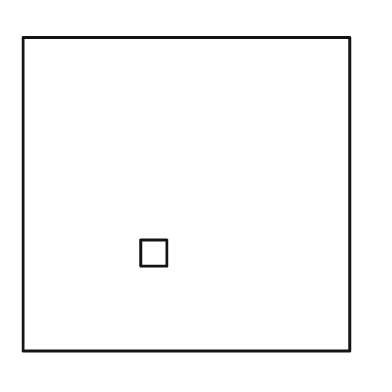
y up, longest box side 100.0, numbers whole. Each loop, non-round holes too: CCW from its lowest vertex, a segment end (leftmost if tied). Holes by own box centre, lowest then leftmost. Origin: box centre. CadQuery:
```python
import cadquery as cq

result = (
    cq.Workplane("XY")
    .moveTo(-50.0, -48.0)
    .lineTo(50.0, -48.0)
    .lineTo(50.0, 48.0)
    .lineTo(-50.0, 48.0)
    .close()
    .moveTo(-14.0, -22.0)
    .lineTo(-6.0, -22.0)
    .lineTo(-6.0, -14.0)
    .lineTo(-14.0, -14.0)
    .close()
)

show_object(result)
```